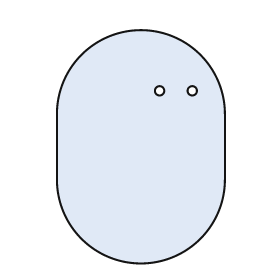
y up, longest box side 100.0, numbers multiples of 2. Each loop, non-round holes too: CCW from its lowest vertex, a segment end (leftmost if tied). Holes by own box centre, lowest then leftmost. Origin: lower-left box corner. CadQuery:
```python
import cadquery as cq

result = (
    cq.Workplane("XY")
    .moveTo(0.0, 36.0)
    .threePointArc((36.0, 0.0), (72.0, 36.0))
    .lineTo(72.0, 64.0)
    .threePointArc((36.0, 100.0), (0.0, 64.0))
    .close()
    .moveTo(44.0, 74.0)
    .circle(2.0)
    .moveTo(58.0, 74.0)
    .circle(2.0)
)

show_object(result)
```